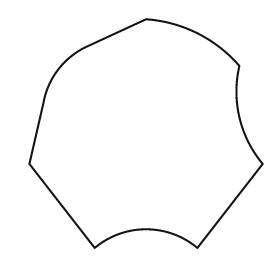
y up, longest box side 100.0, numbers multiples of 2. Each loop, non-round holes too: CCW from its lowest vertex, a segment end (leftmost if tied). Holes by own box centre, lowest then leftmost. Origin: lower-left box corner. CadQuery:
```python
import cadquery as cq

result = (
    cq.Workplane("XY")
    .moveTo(28.0, 0.0)
    .threePointArc((50.0, 8.0), (72.0, 0.0))
    .lineTo(100.0, 36.0)
    .threePointArc((90.0, 56.0), (90.0, 78.0))
    .threePointArc((72.0, 92.0), (50.0, 98.0))
    .lineTo(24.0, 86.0)
    .threePointArc((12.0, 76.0), (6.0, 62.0))
    .lineTo(0.0, 36.0)
    .close()
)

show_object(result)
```